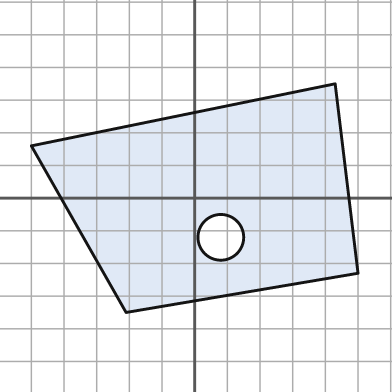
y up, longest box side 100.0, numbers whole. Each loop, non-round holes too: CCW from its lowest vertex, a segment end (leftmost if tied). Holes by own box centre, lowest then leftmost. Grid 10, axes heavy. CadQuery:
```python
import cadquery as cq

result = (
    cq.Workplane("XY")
    .moveTo(-21.0, -35.0)
    .lineTo(50.0, -23.0)
    .lineTo(43.0, 35.0)
    .lineTo(-50.0, 16.0)
    .close()
    .moveTo(8.0, -12.0)
    .circle(7.0)
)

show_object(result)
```